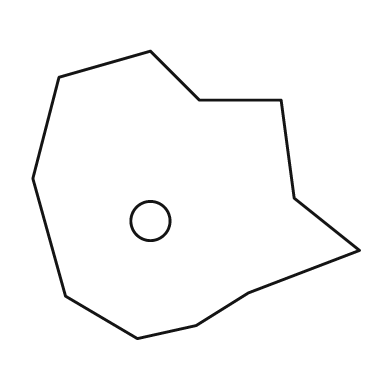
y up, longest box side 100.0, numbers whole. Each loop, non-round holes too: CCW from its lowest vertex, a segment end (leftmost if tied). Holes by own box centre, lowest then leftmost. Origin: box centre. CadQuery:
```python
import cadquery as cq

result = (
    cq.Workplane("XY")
    .moveTo(-18.0, -44.0)
    .lineTo(0.0, -40.0)
    .lineTo(16.0, -30.0)
    .lineTo(50.0, -17.0)
    .lineTo(30.0, -1.0)
    .lineTo(26.0, 29.0)
    .lineTo(1.0, 29.0)
    .lineTo(-14.0, 44.0)
    .lineTo(-42.0, 36.0)
    .lineTo(-50.0, 5.0)
    .lineTo(-40.0, -31.0)
    .close()
    .moveTo(-14.0, -8.0)
    .circle(6.0)
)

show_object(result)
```